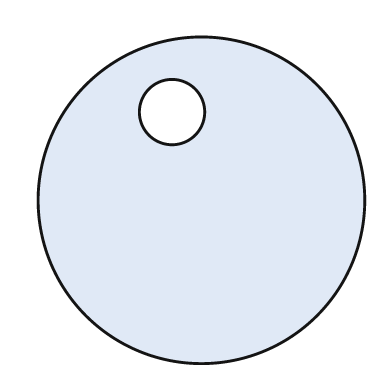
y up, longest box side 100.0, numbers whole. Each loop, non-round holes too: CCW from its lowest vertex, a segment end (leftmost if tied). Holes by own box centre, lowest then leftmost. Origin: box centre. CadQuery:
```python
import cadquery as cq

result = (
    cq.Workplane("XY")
    .moveTo(0.0, 0.0)
    .circle(50.0)
    .moveTo(-9.0, 27.0)
    .circle(10.0)
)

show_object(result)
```